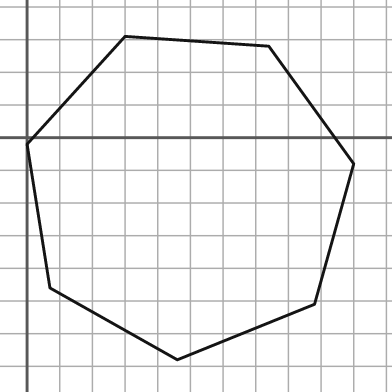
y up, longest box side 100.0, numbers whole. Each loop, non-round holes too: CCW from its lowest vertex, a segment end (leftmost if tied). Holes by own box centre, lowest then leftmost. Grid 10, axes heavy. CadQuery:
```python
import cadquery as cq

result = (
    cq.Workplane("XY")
    .moveTo(46.0, -68.0)
    .lineTo(88.0, -51.0)
    .lineTo(100.0, -8.0)
    .lineTo(74.0, 28.0)
    .lineTo(30.0, 31.0)
    .lineTo(0.0, -2.0)
    .lineTo(7.0, -46.0)
    .close()
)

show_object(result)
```